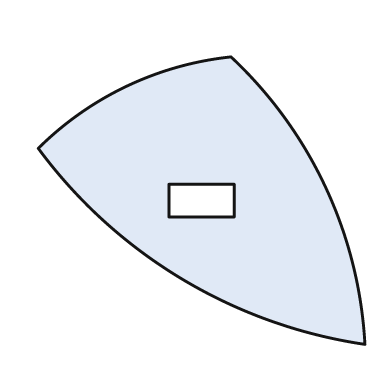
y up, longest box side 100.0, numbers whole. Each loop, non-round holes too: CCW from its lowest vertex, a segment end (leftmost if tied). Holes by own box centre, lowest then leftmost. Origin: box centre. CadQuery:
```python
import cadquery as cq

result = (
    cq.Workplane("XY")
    .moveTo(50.0, -44.0)
    .threePointArc((38.0, 4.0), (9.0, 44.0))
    .threePointArc((-23.0, 35.0), (-50.0, 16.0))
    .threePointArc((-6.0, -24.0), (50.0, -44.0))
    .close()
    .moveTo(-10.0, -5.0)
    .lineTo(10.0, -5.0)
    .lineTo(10.0, 5.0)
    .lineTo(-10.0, 5.0)
    .close()
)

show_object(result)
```